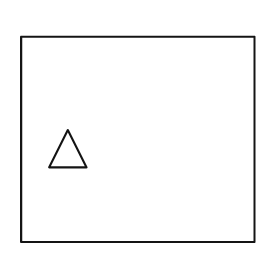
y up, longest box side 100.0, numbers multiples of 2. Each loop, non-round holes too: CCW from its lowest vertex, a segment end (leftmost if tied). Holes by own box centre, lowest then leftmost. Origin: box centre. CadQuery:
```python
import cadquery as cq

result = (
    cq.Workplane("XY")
    .moveTo(-50.0, -44.0)
    .lineTo(50.0, -44.0)
    .lineTo(50.0, 44.0)
    .lineTo(-50.0, 44.0)
    .close()
    .moveTo(-38.0, -12.0)
    .lineTo(-22.0, -12.0)
    .lineTo(-30.0, 4.0)
    .close()
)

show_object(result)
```